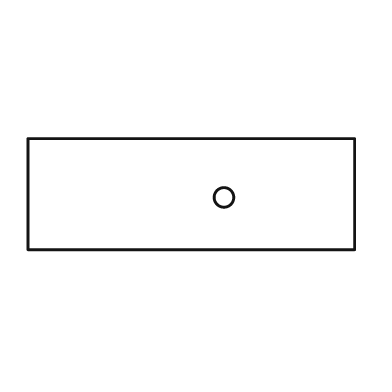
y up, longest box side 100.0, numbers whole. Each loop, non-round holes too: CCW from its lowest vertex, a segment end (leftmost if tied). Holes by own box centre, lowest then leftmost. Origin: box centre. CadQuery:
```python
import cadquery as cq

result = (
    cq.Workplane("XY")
    .moveTo(-50.0, -17.0)
    .lineTo(50.0, -17.0)
    .lineTo(50.0, 17.0)
    .lineTo(-50.0, 17.0)
    .close()
    .moveTo(10.0, -1.0)
    .circle(3.0)
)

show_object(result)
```